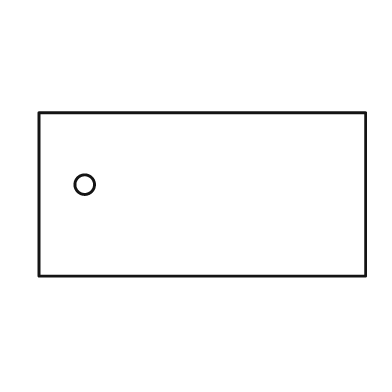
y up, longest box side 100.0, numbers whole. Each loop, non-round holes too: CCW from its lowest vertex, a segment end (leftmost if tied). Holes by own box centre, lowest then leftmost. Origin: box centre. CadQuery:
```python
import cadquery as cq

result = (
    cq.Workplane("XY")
    .moveTo(-50.0, -25.0)
    .lineTo(50.0, -25.0)
    .lineTo(50.0, 25.0)
    .lineTo(-50.0, 25.0)
    .close()
    .moveTo(-36.0, 3.0)
    .circle(3.0)
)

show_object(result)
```